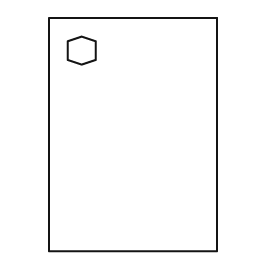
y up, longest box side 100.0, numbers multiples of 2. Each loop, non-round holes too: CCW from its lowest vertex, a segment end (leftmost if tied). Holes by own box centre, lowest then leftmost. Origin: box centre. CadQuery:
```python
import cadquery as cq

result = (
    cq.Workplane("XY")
    .moveTo(-36.0, -50.0)
    .lineTo(36.0, -50.0)
    .lineTo(36.0, 50.0)
    .lineTo(-36.0, 50.0)
    .close()
    .moveTo(-22.0, 30.0)
    .lineTo(-16.0, 32.0)
    .lineTo(-16.0, 40.0)
    .lineTo(-22.0, 42.0)
    .lineTo(-28.0, 40.0)
    .lineTo(-28.0, 32.0)
    .close()
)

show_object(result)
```